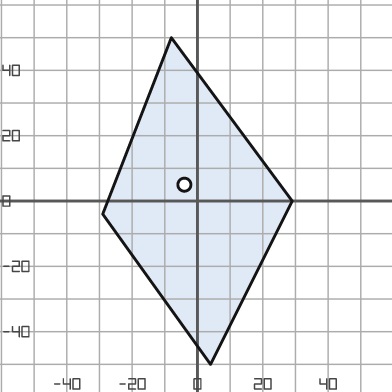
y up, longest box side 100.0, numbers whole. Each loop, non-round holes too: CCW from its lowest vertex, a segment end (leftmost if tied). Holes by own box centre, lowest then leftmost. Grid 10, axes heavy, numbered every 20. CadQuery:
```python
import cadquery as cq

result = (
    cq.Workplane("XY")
    .moveTo(4.0, -50.0)
    .lineTo(29.0, 0.0)
    .lineTo(-8.0, 50.0)
    .lineTo(-29.0, -4.0)
    .close()
    .moveTo(-4.0, 5.0)
    .circle(2.0)
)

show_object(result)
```